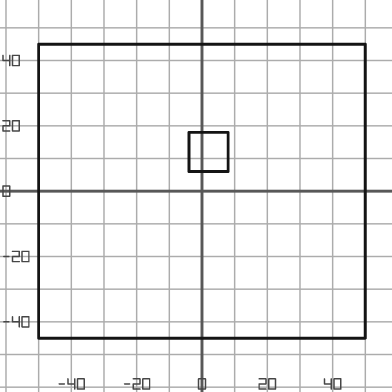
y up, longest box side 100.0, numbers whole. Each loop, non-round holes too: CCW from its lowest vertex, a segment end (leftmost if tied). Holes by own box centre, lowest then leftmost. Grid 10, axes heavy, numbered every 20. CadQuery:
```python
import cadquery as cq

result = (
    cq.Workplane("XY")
    .moveTo(-50.0, -45.0)
    .lineTo(50.0, -45.0)
    .lineTo(50.0, 45.0)
    .lineTo(-50.0, 45.0)
    .close()
    .moveTo(-4.0, 6.0)
    .lineTo(8.0, 6.0)
    .lineTo(8.0, 18.0)
    .lineTo(-4.0, 18.0)
    .close()
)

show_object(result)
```